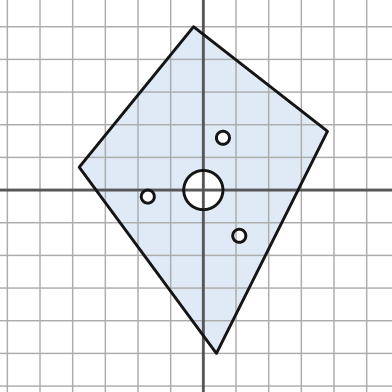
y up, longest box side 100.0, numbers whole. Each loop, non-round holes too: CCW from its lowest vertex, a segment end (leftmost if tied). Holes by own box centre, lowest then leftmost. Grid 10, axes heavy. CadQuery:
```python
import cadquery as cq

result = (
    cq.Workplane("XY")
    .moveTo(4.0, -50.0)
    .lineTo(38.0, 18.0)
    .lineTo(-3.0, 50.0)
    .lineTo(-38.0, 7.0)
    .close()
    .moveTo(11.0, -14.0)
    .circle(2.0)
    .moveTo(-17.0, -2.0)
    .circle(2.0)
    .moveTo(0.0, 0.0)
    .circle(6.0)
    .moveTo(6.0, 16.0)
    .circle(2.0)
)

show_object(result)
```